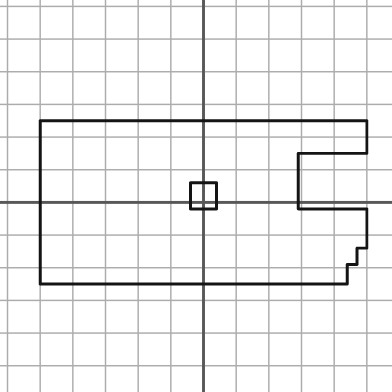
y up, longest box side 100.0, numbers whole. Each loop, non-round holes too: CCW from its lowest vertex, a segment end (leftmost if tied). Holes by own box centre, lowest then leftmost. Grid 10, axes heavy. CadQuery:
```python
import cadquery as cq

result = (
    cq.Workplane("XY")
    .moveTo(-50.0, -25.0)
    .lineTo(44.0, -25.0)
    .lineTo(44.0, -19.0)
    .lineTo(47.0, -19.0)
    .lineTo(47.0, -14.0)
    .lineTo(50.0, -14.0)
    .lineTo(50.0, -2.0)
    .lineTo(29.0, -2.0)
    .lineTo(29.0, 15.0)
    .lineTo(50.0, 15.0)
    .lineTo(50.0, 25.0)
    .lineTo(-50.0, 25.0)
    .close()
    .moveTo(-4.0, -2.0)
    .lineTo(4.0, -2.0)
    .lineTo(4.0, 6.0)
    .lineTo(-4.0, 6.0)
    .close()
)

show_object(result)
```